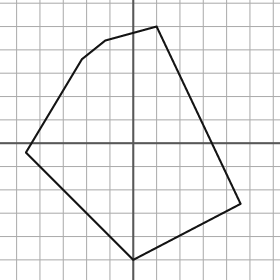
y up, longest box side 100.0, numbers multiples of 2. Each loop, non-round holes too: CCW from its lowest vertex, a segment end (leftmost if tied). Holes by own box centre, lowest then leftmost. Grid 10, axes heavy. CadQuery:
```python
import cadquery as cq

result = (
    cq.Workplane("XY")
    .moveTo(0.0, -50.0)
    .lineTo(46.0, -26.0)
    .lineTo(10.0, 50.0)
    .lineTo(-12.0, 44.0)
    .lineTo(-22.0, 36.0)
    .lineTo(-46.0, -4.0)
    .close()
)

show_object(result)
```